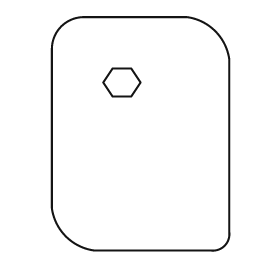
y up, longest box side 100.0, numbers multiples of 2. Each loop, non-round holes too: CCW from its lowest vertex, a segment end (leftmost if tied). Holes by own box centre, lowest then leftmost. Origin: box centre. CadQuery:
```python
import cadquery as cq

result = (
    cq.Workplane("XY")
    .moveTo(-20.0, -50.0)
    .lineTo(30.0, -50.0)
    .threePointArc((36.0, -48.0), (38.0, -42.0))
    .lineTo(38.0, 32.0)
    .threePointArc((32.0, 44.0), (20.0, 50.0))
    .lineTo(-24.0, 50.0)
    .threePointArc((-34.0, 46.0), (-38.0, 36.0))
    .lineTo(-38.0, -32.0)
    .threePointArc((-32.0, -44.0), (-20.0, -50.0))
    .close()
    .moveTo(-12.0, 16.0)
    .lineTo(-4.0, 16.0)
    .lineTo(0.0, 22.0)
    .lineTo(-4.0, 28.0)
    .lineTo(-12.0, 28.0)
    .lineTo(-16.0, 22.0)
    .close()
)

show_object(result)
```